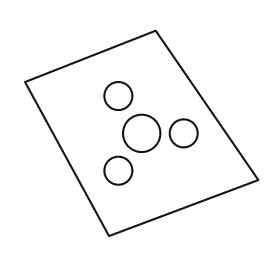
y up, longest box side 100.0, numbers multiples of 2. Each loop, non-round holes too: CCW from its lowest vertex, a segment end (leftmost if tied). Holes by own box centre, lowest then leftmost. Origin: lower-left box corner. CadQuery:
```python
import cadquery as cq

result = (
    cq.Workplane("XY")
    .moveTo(36.0, 0.0)
    .lineTo(100.0, 24.0)
    .lineTo(56.0, 88.0)
    .lineTo(0.0, 66.0)
    .close()
    .moveTo(40.0, 28.0)
    .circle(6.0)
    .moveTo(50.0, 44.0)
    .circle(8.0)
    .moveTo(68.0, 44.0)
    .circle(6.0)
    .moveTo(40.0, 60.0)
    .circle(6.0)
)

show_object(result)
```